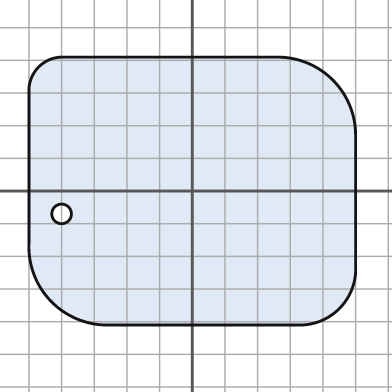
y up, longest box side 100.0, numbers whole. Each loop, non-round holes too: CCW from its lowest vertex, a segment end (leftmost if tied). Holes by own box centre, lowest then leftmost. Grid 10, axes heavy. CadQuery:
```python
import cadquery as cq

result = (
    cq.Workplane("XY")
    .moveTo(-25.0, -41.0)
    .lineTo(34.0, -41.0)
    .threePointArc((45.0, -36.0), (50.0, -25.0))
    .lineTo(50.0, 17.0)
    .threePointArc((43.0, 34.0), (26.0, 41.0))
    .lineTo(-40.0, 41.0)
    .threePointArc((-47.0, 38.0), (-50.0, 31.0))
    .lineTo(-50.0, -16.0)
    .threePointArc((-43.0, -34.0), (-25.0, -41.0))
    .close()
    .moveTo(-40.0, -7.0)
    .circle(3.0)
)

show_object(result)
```